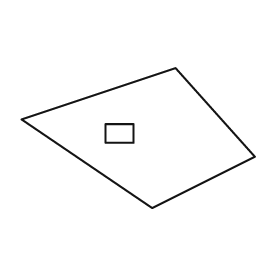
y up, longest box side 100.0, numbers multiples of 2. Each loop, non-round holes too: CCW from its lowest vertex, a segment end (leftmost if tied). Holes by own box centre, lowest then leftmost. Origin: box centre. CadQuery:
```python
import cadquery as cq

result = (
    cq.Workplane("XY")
    .moveTo(6.0, -30.0)
    .lineTo(50.0, -8.0)
    .lineTo(16.0, 30.0)
    .lineTo(-50.0, 8.0)
    .close()
    .moveTo(-14.0, -2.0)
    .lineTo(-2.0, -2.0)
    .lineTo(-2.0, 6.0)
    .lineTo(-14.0, 6.0)
    .close()
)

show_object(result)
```